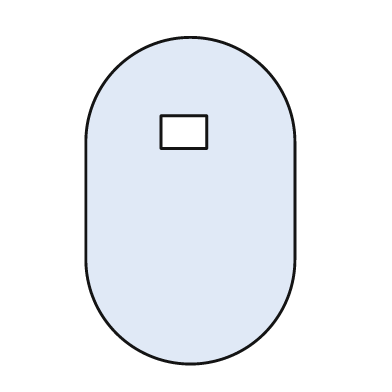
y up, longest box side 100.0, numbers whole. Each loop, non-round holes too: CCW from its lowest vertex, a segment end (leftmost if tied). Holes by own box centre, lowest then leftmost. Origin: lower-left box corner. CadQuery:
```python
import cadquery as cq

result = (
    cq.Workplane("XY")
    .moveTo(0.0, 32.0)
    .threePointArc((32.0, 0.0), (64.0, 32.0))
    .lineTo(64.0, 68.0)
    .threePointArc((32.0, 100.0), (0.0, 68.0))
    .close()
    .moveTo(23.0, 66.0)
    .lineTo(37.0, 66.0)
    .lineTo(37.0, 76.0)
    .lineTo(23.0, 76.0)
    .close()
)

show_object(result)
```